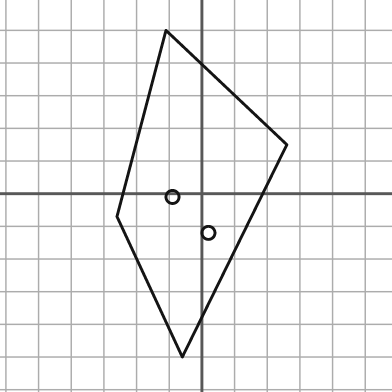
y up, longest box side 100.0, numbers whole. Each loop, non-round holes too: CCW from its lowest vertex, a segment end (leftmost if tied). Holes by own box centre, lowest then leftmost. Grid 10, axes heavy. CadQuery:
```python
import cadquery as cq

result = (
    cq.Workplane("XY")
    .moveTo(-6.0, -50.0)
    .lineTo(26.0, 15.0)
    .lineTo(-11.0, 50.0)
    .lineTo(-26.0, -7.0)
    .close()
    .moveTo(2.0, -12.0)
    .circle(2.0)
    .moveTo(-9.0, -1.0)
    .circle(2.0)
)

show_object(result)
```